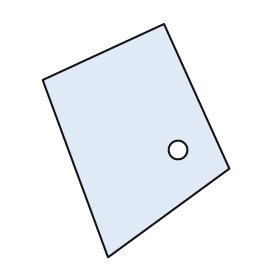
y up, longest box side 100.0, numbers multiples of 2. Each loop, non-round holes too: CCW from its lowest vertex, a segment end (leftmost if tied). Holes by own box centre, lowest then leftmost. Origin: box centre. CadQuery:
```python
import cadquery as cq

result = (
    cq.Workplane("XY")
    .moveTo(-12.0, -50.0)
    .lineTo(40.0, -12.0)
    .lineTo(12.0, 50.0)
    .lineTo(-40.0, 26.0)
    .close()
    .moveTo(18.0, -4.0)
    .circle(4.0)
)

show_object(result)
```